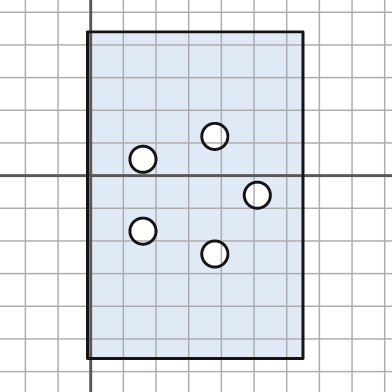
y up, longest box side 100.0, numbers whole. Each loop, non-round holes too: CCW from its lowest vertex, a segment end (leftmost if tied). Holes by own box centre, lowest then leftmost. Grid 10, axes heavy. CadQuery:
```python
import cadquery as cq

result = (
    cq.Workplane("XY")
    .moveTo(-1.0, -56.0)
    .lineTo(65.0, -56.0)
    .lineTo(65.0, 44.0)
    .lineTo(-1.0, 44.0)
    .close()
    .moveTo(38.0, -24.0)
    .circle(4.0)
    .moveTo(16.0, -17.0)
    .circle(4.0)
    .moveTo(51.0, -6.0)
    .circle(4.0)
    .moveTo(16.0, 5.0)
    .circle(4.0)
    .moveTo(38.0, 12.0)
    .circle(4.0)
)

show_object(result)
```